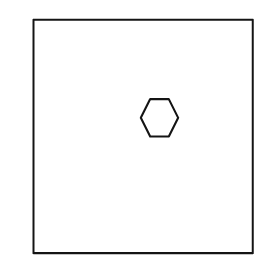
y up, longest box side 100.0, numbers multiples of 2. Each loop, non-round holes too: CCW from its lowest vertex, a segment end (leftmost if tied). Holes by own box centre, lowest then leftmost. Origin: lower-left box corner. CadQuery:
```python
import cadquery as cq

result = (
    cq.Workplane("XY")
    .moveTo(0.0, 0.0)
    .lineTo(94.0, 0.0)
    .lineTo(94.0, 100.0)
    .lineTo(0.0, 100.0)
    .close()
    .moveTo(50.0, 50.0)
    .lineTo(58.0, 50.0)
    .lineTo(62.0, 58.0)
    .lineTo(58.0, 66.0)
    .lineTo(50.0, 66.0)
    .lineTo(46.0, 58.0)
    .close()
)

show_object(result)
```